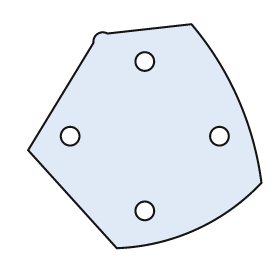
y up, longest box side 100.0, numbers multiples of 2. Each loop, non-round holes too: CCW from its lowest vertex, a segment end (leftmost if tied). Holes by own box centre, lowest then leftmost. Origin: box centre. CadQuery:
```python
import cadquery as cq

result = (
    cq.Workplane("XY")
    .moveTo(-12.0, -48.0)
    .threePointArc((22.0, -40.0), (50.0, -20.0))
    .threePointArc((40.0, 16.0), (20.0, 48.0))
    .lineTo(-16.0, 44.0)
    .threePointArc((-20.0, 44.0), (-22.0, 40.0))
    .lineTo(-50.0, -6.0)
    .close()
    .moveTo(0.0, -32.0)
    .circle(4.0)
    .moveTo(-32.0, 0.0)
    .circle(4.0)
    .moveTo(32.0, 0.0)
    .circle(4.0)
    .moveTo(0.0, 32.0)
    .circle(4.0)
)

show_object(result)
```